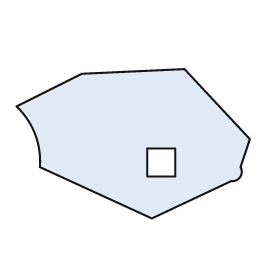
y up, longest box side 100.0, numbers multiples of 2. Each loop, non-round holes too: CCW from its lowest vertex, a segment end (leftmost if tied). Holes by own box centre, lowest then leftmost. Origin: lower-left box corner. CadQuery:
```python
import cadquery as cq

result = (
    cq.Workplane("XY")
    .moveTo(58.0, 0.0)
    .lineTo(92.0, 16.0)
    .threePointArc((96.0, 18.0), (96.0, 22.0))
    .lineTo(100.0, 34.0)
    .lineTo(72.0, 64.0)
    .lineTo(28.0, 62.0)
    .lineTo(0.0, 48.0)
    .threePointArc((8.0, 36.0), (10.0, 22.0))
    .close()
    .moveTo(56.0, 18.0)
    .lineTo(68.0, 18.0)
    .lineTo(68.0, 30.0)
    .lineTo(56.0, 30.0)
    .close()
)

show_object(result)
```